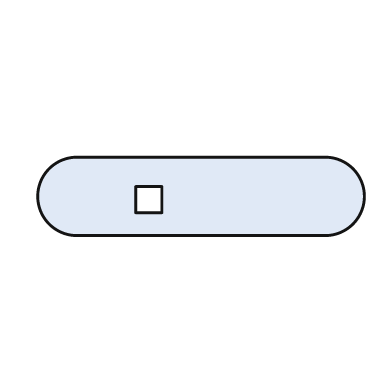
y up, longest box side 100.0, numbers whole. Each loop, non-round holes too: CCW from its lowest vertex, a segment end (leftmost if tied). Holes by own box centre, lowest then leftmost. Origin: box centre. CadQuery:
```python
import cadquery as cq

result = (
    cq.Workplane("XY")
    .moveTo(-38.0, -12.0)
    .lineTo(38.0, -12.0)
    .threePointArc((50.0, 0.0), (38.0, 12.0))
    .lineTo(-38.0, 12.0)
    .threePointArc((-50.0, 0.0), (-38.0, -12.0))
    .close()
    .moveTo(-20.0, -5.0)
    .lineTo(-12.0, -5.0)
    .lineTo(-12.0, 3.0)
    .lineTo(-20.0, 3.0)
    .close()
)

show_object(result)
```